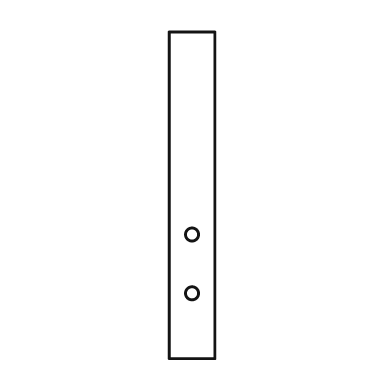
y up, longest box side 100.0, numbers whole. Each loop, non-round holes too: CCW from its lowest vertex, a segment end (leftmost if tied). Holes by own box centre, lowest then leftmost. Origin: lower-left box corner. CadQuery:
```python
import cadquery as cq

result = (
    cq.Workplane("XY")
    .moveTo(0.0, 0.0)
    .lineTo(14.0, 0.0)
    .lineTo(14.0, 100.0)
    .lineTo(0.0, 100.0)
    .close()
    .moveTo(7.0, 20.0)
    .circle(2.0)
    .moveTo(7.0, 38.0)
    .circle(2.0)
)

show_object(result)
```